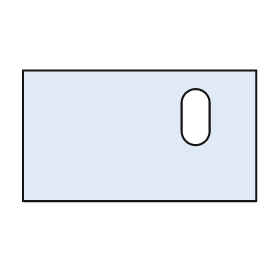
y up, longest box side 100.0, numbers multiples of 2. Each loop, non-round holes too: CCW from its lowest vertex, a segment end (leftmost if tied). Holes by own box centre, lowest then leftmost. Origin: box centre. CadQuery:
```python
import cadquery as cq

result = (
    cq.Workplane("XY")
    .moveTo(-50.0, -28.0)
    .lineTo(50.0, -28.0)
    .lineTo(50.0, 28.0)
    .lineTo(-50.0, 28.0)
    .close()
    .moveTo(18.0, 2.0)
    .threePointArc((24.0, -4.0), (30.0, 2.0))
    .lineTo(30.0, 14.0)
    .threePointArc((24.0, 20.0), (18.0, 14.0))
    .close()
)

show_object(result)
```